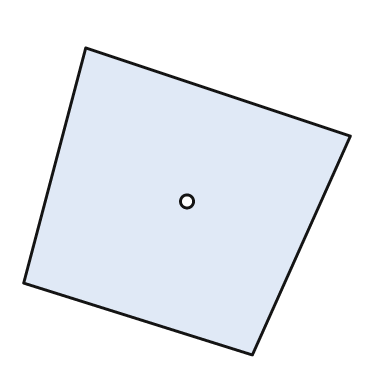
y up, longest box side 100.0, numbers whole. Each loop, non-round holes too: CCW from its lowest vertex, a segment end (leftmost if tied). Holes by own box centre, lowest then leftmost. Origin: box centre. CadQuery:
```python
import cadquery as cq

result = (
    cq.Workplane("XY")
    .moveTo(20.0, -47.0)
    .lineTo(50.0, 20.0)
    .lineTo(-31.0, 47.0)
    .lineTo(-50.0, -25.0)
    .close()
    .moveTo(0.0, 0.0)
    .circle(2.0)
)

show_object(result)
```